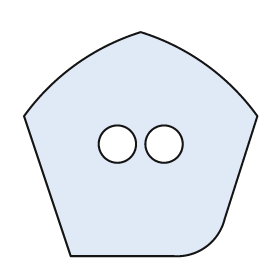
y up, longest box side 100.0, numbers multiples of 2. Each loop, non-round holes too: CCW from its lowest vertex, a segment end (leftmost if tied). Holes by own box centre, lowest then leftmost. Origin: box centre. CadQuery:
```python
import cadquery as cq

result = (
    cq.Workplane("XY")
    .moveTo(-30.0, -48.0)
    .lineTo(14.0, -48.0)
    .threePointArc((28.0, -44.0), (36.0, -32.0))
    .lineTo(50.0, 12.0)
    .threePointArc((28.0, 34.0), (0.0, 48.0))
    .threePointArc((-28.0, 34.0), (-50.0, 12.0))
    .close()
    .moveTo(-10.0, 0.0)
    .circle(8.0)
    .moveTo(10.0, 0.0)
    .circle(8.0)
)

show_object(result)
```